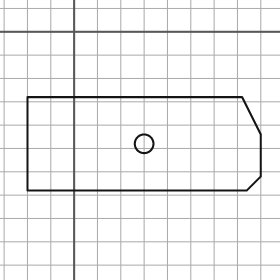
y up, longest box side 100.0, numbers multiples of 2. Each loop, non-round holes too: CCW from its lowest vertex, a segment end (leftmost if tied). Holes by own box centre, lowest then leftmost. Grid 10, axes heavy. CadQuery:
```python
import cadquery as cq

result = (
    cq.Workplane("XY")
    .moveTo(-20.0, -68.0)
    .lineTo(74.0, -68.0)
    .lineTo(80.0, -62.0)
    .lineTo(80.0, -44.0)
    .lineTo(72.0, -28.0)
    .lineTo(-20.0, -28.0)
    .close()
    .moveTo(30.0, -48.0)
    .circle(4.0)
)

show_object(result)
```